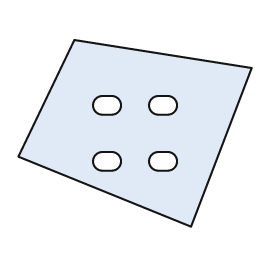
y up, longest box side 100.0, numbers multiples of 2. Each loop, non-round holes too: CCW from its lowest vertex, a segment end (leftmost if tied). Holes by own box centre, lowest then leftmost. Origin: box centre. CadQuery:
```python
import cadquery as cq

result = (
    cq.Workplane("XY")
    .moveTo(24.0, -40.0)
    .lineTo(50.0, 28.0)
    .lineTo(-26.0, 40.0)
    .lineTo(-50.0, -10.0)
    .close()
    .moveTo(-14.0, -16.0)
    .lineTo(-10.0, -16.0)
    .threePointArc((-6.0, -12.0), (-10.0, -8.0))
    .lineTo(-14.0, -8.0)
    .threePointArc((-18.0, -12.0), (-14.0, -16.0))
    .close()
    .moveTo(10.0, -16.0)
    .lineTo(14.0, -16.0)
    .threePointArc((18.0, -12.0), (14.0, -8.0))
    .lineTo(10.0, -8.0)
    .threePointArc((6.0, -12.0), (10.0, -16.0))
    .close()
    .moveTo(-14.0, 8.0)
    .lineTo(-10.0, 8.0)
    .threePointArc((-6.0, 12.0), (-10.0, 16.0))
    .lineTo(-14.0, 16.0)
    .threePointArc((-18.0, 12.0), (-14.0, 8.0))
    .close()
    .moveTo(10.0, 8.0)
    .lineTo(14.0, 8.0)
    .threePointArc((18.0, 12.0), (14.0, 16.0))
    .lineTo(10.0, 16.0)
    .threePointArc((6.0, 12.0), (10.0, 8.0))
    .close()
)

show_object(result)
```